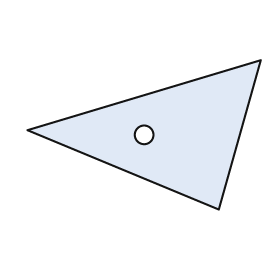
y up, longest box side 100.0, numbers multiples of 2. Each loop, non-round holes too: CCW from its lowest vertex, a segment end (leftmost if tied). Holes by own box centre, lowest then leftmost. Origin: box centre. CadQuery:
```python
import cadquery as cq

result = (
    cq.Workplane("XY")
    .moveTo(32.0, -32.0)
    .lineTo(50.0, 32.0)
    .lineTo(-50.0, 2.0)
    .close()
    .moveTo(0.0, 0.0)
    .circle(4.0)
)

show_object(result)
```